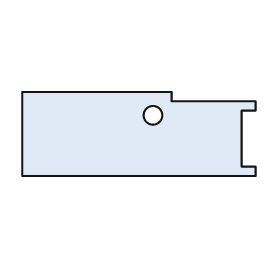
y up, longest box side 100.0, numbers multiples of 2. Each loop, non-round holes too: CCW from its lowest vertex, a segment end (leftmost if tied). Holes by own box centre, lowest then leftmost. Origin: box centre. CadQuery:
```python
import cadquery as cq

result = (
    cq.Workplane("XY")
    .moveTo(-50.0, -18.0)
    .lineTo(50.0, -18.0)
    .lineTo(50.0, -14.0)
    .lineTo(44.0, -14.0)
    .lineTo(44.0, 10.0)
    .lineTo(50.0, 10.0)
    .lineTo(50.0, 14.0)
    .lineTo(14.0, 14.0)
    .lineTo(14.0, 18.0)
    .lineTo(-50.0, 18.0)
    .close()
    .moveTo(6.0, 8.0)
    .circle(4.0)
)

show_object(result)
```